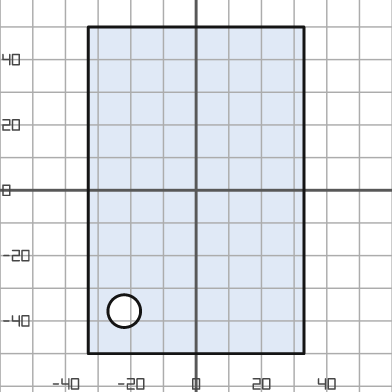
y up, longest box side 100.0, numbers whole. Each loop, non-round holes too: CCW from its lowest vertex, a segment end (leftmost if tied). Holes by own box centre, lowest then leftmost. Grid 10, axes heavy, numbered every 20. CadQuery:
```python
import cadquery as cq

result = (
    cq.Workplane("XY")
    .moveTo(-33.0, -50.0)
    .lineTo(33.0, -50.0)
    .lineTo(33.0, 50.0)
    .lineTo(-33.0, 50.0)
    .close()
    .moveTo(-22.0, -37.0)
    .circle(5.0)
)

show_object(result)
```